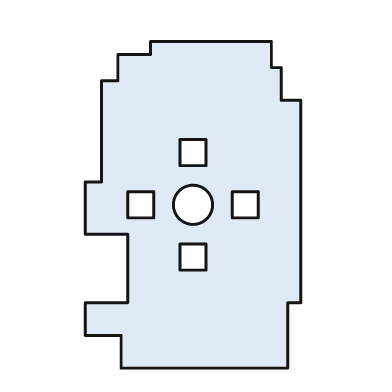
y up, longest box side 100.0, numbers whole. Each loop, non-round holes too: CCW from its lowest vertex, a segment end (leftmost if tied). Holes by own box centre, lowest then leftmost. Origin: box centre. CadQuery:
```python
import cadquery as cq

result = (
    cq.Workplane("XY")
    .moveTo(-22.0, -50.0)
    .lineTo(29.0, -50.0)
    .lineTo(29.0, -30.0)
    .lineTo(33.0, -30.0)
    .lineTo(33.0, 32.0)
    .lineTo(27.0, 32.0)
    .lineTo(27.0, 42.0)
    .lineTo(24.0, 42.0)
    .lineTo(24.0, 50.0)
    .lineTo(-13.0, 50.0)
    .lineTo(-13.0, 46.0)
    .lineTo(-23.0, 46.0)
    .lineTo(-23.0, 38.0)
    .lineTo(-28.0, 38.0)
    .lineTo(-28.0, 7.0)
    .lineTo(-33.0, 7.0)
    .lineTo(-33.0, -9.0)
    .lineTo(-20.0, -9.0)
    .lineTo(-20.0, -30.0)
    .lineTo(-33.0, -30.0)
    .lineTo(-33.0, -40.0)
    .lineTo(-22.0, -40.0)
    .close()
    .moveTo(-4.0, -20.0)
    .lineTo(4.0, -20.0)
    .lineTo(4.0, -12.0)
    .lineTo(-4.0, -12.0)
    .close()
    .moveTo(-20.0, -4.0)
    .lineTo(-12.0, -4.0)
    .lineTo(-12.0, 4.0)
    .lineTo(-20.0, 4.0)
    .close()
    .moveTo(0.0, 0.0)
    .circle(6.0)
    .moveTo(12.0, -4.0)
    .lineTo(20.0, -4.0)
    .lineTo(20.0, 4.0)
    .lineTo(12.0, 4.0)
    .close()
    .moveTo(-4.0, 12.0)
    .lineTo(4.0, 12.0)
    .lineTo(4.0, 20.0)
    .lineTo(-4.0, 20.0)
    .close()
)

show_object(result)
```